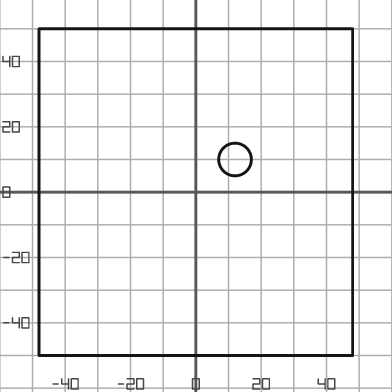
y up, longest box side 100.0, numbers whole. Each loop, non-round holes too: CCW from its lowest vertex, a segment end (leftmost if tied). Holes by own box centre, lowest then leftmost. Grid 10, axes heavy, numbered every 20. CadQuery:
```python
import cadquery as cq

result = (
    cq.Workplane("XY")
    .moveTo(-48.0, -50.0)
    .lineTo(48.0, -50.0)
    .lineTo(48.0, 50.0)
    .lineTo(-48.0, 50.0)
    .close()
    .moveTo(12.0, 10.0)
    .circle(5.0)
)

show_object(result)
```